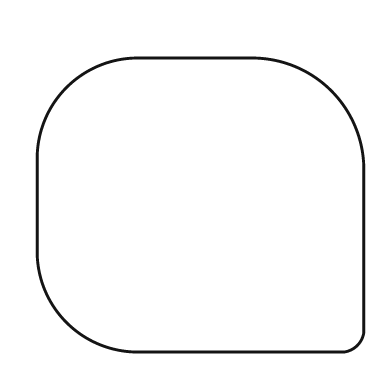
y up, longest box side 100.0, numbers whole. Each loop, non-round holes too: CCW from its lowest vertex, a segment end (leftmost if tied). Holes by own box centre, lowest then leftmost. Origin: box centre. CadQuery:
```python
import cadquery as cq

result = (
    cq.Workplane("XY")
    .moveTo(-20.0, -45.0)
    .lineTo(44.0, -45.0)
    .threePointArc((48.0, -43.0), (50.0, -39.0))
    .lineTo(50.0, 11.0)
    .threePointArc((40.0, 35.0), (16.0, 45.0))
    .lineTo(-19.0, 45.0)
    .threePointArc((-41.0, 36.0), (-50.0, 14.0))
    .lineTo(-50.0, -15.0)
    .threePointArc((-41.0, -36.0), (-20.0, -45.0))
    .close()
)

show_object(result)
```